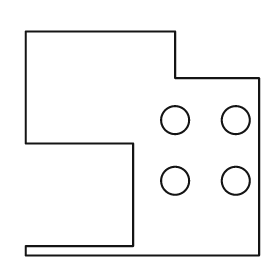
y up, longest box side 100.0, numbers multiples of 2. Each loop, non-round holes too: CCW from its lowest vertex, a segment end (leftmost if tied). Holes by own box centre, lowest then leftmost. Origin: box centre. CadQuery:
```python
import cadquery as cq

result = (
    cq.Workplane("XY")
    .moveTo(-50.0, -48.0)
    .lineTo(50.0, -48.0)
    .lineTo(50.0, 28.0)
    .lineTo(14.0, 28.0)
    .lineTo(14.0, 48.0)
    .lineTo(-50.0, 48.0)
    .lineTo(-50.0, 0.0)
    .lineTo(-4.0, 0.0)
    .lineTo(-4.0, -44.0)
    .lineTo(-50.0, -44.0)
    .close()
    .moveTo(14.0, -16.0)
    .circle(6.0)
    .moveTo(40.0, -16.0)
    .circle(6.0)
    .moveTo(14.0, 10.0)
    .circle(6.0)
    .moveTo(40.0, 10.0)
    .circle(6.0)
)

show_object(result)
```